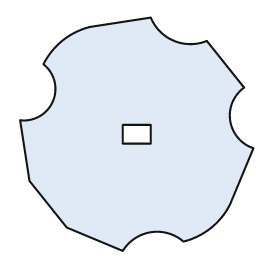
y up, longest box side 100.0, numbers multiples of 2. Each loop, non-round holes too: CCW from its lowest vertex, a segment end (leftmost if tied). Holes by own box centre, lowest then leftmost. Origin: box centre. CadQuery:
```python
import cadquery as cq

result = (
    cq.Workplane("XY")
    .moveTo(-6.0, -50.0)
    .threePointArc((6.0, -42.0), (20.0, -46.0))
    .threePointArc((32.0, -40.0), (40.0, -30.0))
    .lineTo(50.0, -6.0)
    .threePointArc((40.0, 6.0), (46.0, 20.0))
    .lineTo(30.0, 40.0)
    .threePointArc((16.0, 40.0), (6.0, 50.0))
    .lineTo(-20.0, 46.0)
    .threePointArc((-32.0, 40.0), (-40.0, 30.0))
    .threePointArc((-36.0, 14.0), (-50.0, 6.0))
    .lineTo(-46.0, -20.0)
    .lineTo(-30.0, -40.0)
    .close()
    .moveTo(-6.0, -4.0)
    .lineTo(6.0, -4.0)
    .lineTo(6.0, 4.0)
    .lineTo(-6.0, 4.0)
    .close()
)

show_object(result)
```